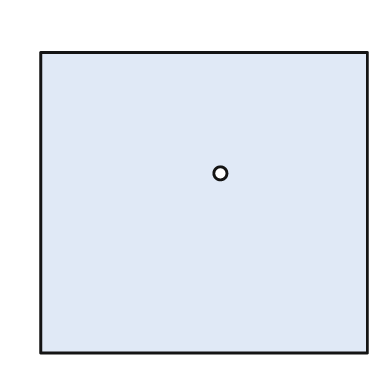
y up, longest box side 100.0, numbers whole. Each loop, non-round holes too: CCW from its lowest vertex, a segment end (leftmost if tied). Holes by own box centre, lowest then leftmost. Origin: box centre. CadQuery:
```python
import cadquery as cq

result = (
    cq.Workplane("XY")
    .moveTo(-50.0, -46.0)
    .lineTo(50.0, -46.0)
    .lineTo(50.0, 46.0)
    .lineTo(-50.0, 46.0)
    .close()
    .moveTo(5.0, 9.0)
    .circle(2.0)
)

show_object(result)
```